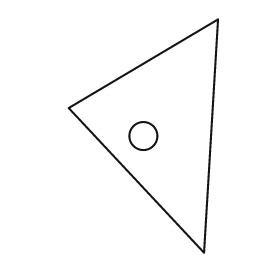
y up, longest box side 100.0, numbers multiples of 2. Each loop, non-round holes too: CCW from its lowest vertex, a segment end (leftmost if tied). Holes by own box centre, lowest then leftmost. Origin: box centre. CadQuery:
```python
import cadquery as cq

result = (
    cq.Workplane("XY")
    .moveTo(26.0, -50.0)
    .lineTo(32.0, 50.0)
    .lineTo(-32.0, 12.0)
    .close()
    .moveTo(0.0, 0.0)
    .circle(6.0)
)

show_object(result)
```